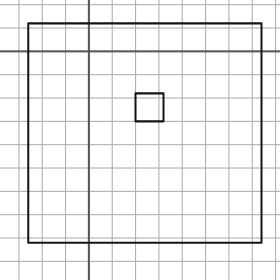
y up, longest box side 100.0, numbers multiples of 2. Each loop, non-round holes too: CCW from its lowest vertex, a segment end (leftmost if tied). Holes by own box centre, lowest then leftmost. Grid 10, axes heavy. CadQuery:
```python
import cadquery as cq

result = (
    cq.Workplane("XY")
    .moveTo(-26.0, -82.0)
    .lineTo(74.0, -82.0)
    .lineTo(74.0, 12.0)
    .lineTo(-26.0, 12.0)
    .close()
    .moveTo(20.0, -30.0)
    .lineTo(32.0, -30.0)
    .lineTo(32.0, -18.0)
    .lineTo(20.0, -18.0)
    .close()
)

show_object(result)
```